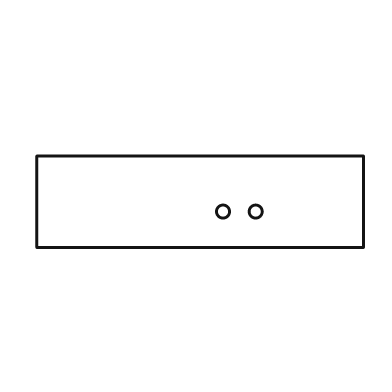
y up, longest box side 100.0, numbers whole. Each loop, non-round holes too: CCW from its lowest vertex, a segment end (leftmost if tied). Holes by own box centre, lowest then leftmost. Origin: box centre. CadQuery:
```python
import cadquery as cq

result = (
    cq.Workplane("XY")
    .moveTo(-50.0, -14.0)
    .lineTo(50.0, -14.0)
    .lineTo(50.0, 14.0)
    .lineTo(-50.0, 14.0)
    .close()
    .moveTo(7.0, -3.0)
    .circle(2.0)
    .moveTo(17.0, -3.0)
    .circle(2.0)
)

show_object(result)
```